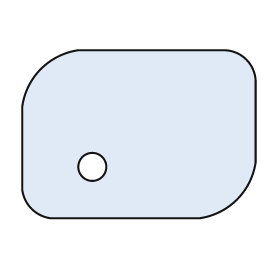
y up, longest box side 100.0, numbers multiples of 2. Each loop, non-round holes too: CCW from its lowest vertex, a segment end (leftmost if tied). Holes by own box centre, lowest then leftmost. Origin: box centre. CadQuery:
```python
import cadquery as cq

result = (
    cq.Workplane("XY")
    .moveTo(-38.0, -36.0)
    .lineTo(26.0, -36.0)
    .threePointArc((42.0, -28.0), (50.0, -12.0))
    .lineTo(50.0, 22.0)
    .threePointArc((46.0, 32.0), (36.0, 36.0))
    .lineTo(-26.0, 36.0)
    .threePointArc((-42.0, 28.0), (-50.0, 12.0))
    .lineTo(-50.0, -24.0)
    .threePointArc((-46.0, -32.0), (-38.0, -36.0))
    .close()
    .moveTo(-20.0, -14.0)
    .circle(6.0)
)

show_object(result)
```